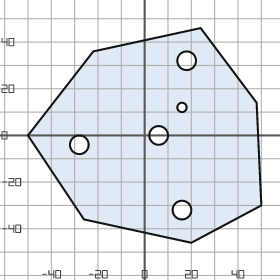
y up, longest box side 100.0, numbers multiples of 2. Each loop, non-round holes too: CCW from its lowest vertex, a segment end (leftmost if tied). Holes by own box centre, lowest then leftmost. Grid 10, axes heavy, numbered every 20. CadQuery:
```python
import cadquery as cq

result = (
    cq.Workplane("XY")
    .moveTo(20.0, -46.0)
    .lineTo(50.0, -30.0)
    .lineTo(48.0, 14.0)
    .lineTo(24.0, 46.0)
    .lineTo(-22.0, 36.0)
    .lineTo(-50.0, 0.0)
    .lineTo(-26.0, -36.0)
    .close()
    .moveTo(16.0, -32.0)
    .circle(4.0)
    .moveTo(-28.0, -4.0)
    .circle(4.0)
    .moveTo(6.0, 0.0)
    .circle(4.0)
    .moveTo(16.0, 12.0)
    .circle(2.0)
    .moveTo(18.0, 32.0)
    .circle(4.0)
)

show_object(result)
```